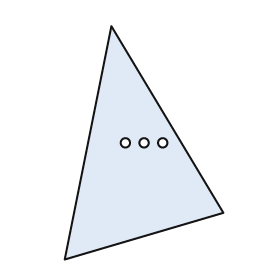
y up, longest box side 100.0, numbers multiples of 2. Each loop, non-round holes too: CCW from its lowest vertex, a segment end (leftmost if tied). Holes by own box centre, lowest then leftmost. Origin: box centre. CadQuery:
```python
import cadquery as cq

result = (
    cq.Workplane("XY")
    .moveTo(-34.0, -50.0)
    .lineTo(34.0, -30.0)
    .lineTo(-14.0, 50.0)
    .close()
    .moveTo(-8.0, 0.0)
    .circle(2.0)
    .moveTo(0.0, 0.0)
    .circle(2.0)
    .moveTo(8.0, 0.0)
    .circle(2.0)
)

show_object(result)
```